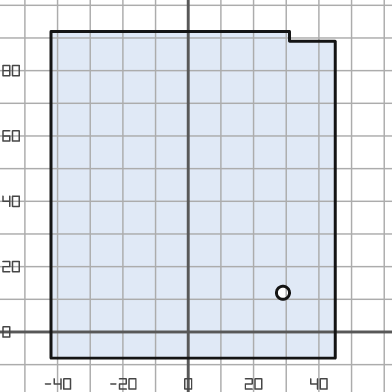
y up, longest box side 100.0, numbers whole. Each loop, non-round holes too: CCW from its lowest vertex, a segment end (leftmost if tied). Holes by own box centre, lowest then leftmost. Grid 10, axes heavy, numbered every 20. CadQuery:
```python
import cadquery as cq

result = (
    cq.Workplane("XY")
    .moveTo(-42.0, -8.0)
    .lineTo(45.0, -8.0)
    .lineTo(45.0, 89.0)
    .lineTo(31.0, 89.0)
    .lineTo(31.0, 92.0)
    .lineTo(-42.0, 92.0)
    .close()
    .moveTo(29.0, 12.0)
    .circle(2.0)
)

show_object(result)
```